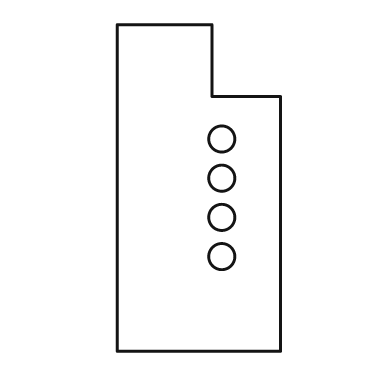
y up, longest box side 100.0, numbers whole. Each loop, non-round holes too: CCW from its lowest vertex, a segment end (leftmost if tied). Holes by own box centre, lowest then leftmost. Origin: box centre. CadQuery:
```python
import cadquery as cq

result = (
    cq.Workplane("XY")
    .moveTo(-25.0, -50.0)
    .lineTo(25.0, -50.0)
    .lineTo(25.0, 28.0)
    .lineTo(4.0, 28.0)
    .lineTo(4.0, 50.0)
    .lineTo(-25.0, 50.0)
    .close()
    .moveTo(7.0, -21.0)
    .circle(4.0)
    .moveTo(7.0, -9.0)
    .circle(4.0)
    .moveTo(7.0, 3.0)
    .circle(4.0)
    .moveTo(7.0, 15.0)
    .circle(4.0)
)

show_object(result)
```